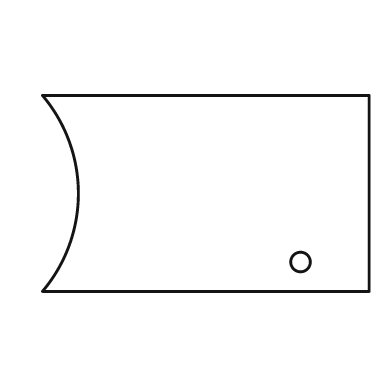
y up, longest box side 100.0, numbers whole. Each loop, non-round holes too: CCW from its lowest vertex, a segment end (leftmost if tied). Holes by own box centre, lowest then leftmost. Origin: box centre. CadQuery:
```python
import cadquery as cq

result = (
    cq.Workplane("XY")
    .moveTo(-50.0, -30.0)
    .lineTo(50.0, -30.0)
    .lineTo(50.0, 30.0)
    .lineTo(-50.0, 30.0)
    .threePointArc((-39.0, 0.0), (-50.0, -30.0))
    .close()
    .moveTo(29.0, -21.0)
    .circle(3.0)
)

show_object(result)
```